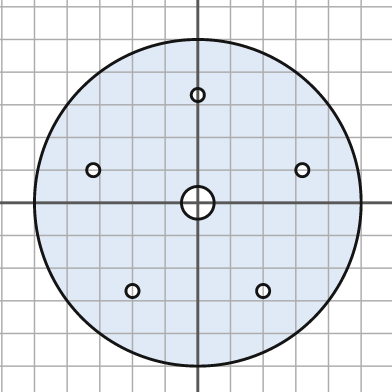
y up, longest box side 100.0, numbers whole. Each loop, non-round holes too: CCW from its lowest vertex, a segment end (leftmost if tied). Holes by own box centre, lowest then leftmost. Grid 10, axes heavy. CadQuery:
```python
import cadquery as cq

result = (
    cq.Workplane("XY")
    .moveTo(0.0, 0.0)
    .circle(50.0)
    .moveTo(-20.0, -27.0)
    .circle(2.0)
    .moveTo(20.0, -27.0)
    .circle(2.0)
    .moveTo(0.0, 0.0)
    .circle(5.0)
    .moveTo(-32.0, 10.0)
    .circle(2.0)
    .moveTo(32.0, 10.0)
    .circle(2.0)
    .moveTo(0.0, 33.0)
    .circle(2.0)
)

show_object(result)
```